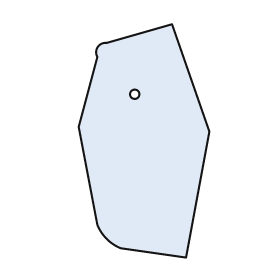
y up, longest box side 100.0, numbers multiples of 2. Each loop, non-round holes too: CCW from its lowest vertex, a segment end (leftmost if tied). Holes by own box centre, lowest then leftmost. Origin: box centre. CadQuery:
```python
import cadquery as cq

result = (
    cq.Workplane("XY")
    .moveTo(18.0, -50.0)
    .lineTo(28.0, 4.0)
    .lineTo(12.0, 50.0)
    .lineTo(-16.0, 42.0)
    .threePointArc((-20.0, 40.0), (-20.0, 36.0))
    .lineTo(-28.0, 6.0)
    .lineTo(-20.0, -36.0)
    .threePointArc((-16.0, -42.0), (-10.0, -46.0))
    .close()
    .moveTo(-4.0, 20.0)
    .circle(2.0)
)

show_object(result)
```